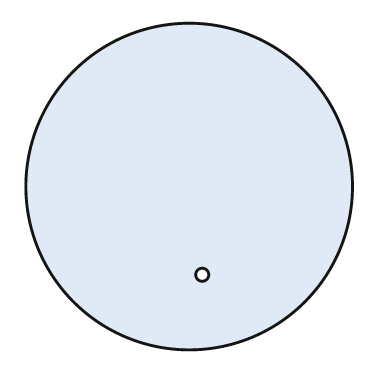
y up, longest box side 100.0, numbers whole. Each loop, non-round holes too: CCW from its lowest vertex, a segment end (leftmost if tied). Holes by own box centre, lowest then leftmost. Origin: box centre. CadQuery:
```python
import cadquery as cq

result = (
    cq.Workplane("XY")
    .moveTo(0.0, 0.0)
    .circle(50.0)
    .moveTo(4.0, -27.0)
    .circle(2.0)
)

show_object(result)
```